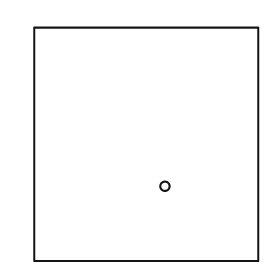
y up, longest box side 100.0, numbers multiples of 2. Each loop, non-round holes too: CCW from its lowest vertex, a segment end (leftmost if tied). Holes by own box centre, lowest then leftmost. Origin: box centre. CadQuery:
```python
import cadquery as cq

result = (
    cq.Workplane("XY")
    .moveTo(-48.0, -50.0)
    .lineTo(48.0, -50.0)
    .lineTo(48.0, 50.0)
    .lineTo(-48.0, 50.0)
    .close()
    .moveTo(8.0, -18.0)
    .circle(2.0)
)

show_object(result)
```